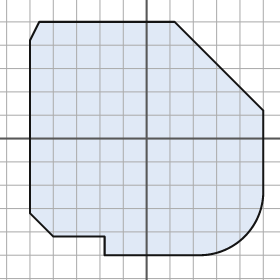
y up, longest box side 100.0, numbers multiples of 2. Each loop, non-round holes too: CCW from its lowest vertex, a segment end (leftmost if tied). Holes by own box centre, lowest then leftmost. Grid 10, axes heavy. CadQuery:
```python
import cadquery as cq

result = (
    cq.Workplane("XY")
    .moveTo(-18.0, -50.0)
    .lineTo(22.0, -50.0)
    .threePointArc((42.0, -42.0), (50.0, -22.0))
    .lineTo(50.0, 12.0)
    .lineTo(12.0, 50.0)
    .lineTo(-46.0, 50.0)
    .lineTo(-50.0, 42.0)
    .lineTo(-50.0, -32.0)
    .lineTo(-40.0, -42.0)
    .lineTo(-18.0, -42.0)
    .close()
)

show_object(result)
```